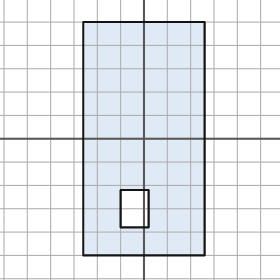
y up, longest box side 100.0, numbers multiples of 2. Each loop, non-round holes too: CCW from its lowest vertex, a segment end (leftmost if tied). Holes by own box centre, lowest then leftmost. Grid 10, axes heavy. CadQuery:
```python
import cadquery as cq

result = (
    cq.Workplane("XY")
    .moveTo(-26.0, -50.0)
    .lineTo(26.0, -50.0)
    .lineTo(26.0, 50.0)
    .lineTo(-26.0, 50.0)
    .close()
    .moveTo(-10.0, -38.0)
    .lineTo(2.0, -38.0)
    .lineTo(2.0, -22.0)
    .lineTo(-10.0, -22.0)
    .close()
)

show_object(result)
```